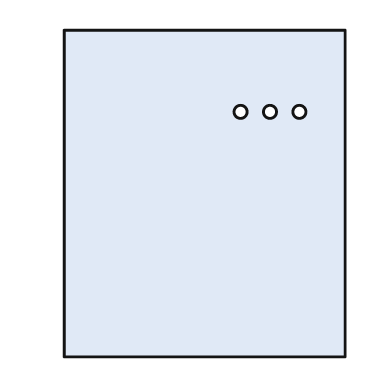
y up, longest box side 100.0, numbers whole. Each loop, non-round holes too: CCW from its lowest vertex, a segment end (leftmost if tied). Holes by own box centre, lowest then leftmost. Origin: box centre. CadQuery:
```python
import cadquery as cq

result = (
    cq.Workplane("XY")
    .moveTo(-43.0, -50.0)
    .lineTo(43.0, -50.0)
    .lineTo(43.0, 50.0)
    .lineTo(-43.0, 50.0)
    .close()
    .moveTo(11.0, 25.0)
    .circle(2.0)
    .moveTo(20.0, 25.0)
    .circle(2.0)
    .moveTo(29.0, 25.0)
    .circle(2.0)
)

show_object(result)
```